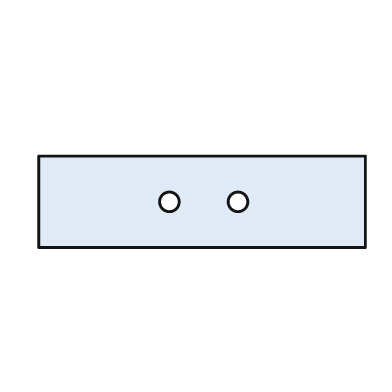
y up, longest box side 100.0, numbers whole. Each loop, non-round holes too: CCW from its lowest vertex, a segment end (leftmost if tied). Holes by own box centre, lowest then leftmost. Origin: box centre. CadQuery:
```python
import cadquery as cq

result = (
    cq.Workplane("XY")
    .moveTo(-50.0, -14.0)
    .lineTo(50.0, -14.0)
    .lineTo(50.0, 14.0)
    .lineTo(-50.0, 14.0)
    .close()
    .moveTo(-10.0, 0.0)
    .circle(3.0)
    .moveTo(11.0, 0.0)
    .circle(3.0)
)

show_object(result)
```